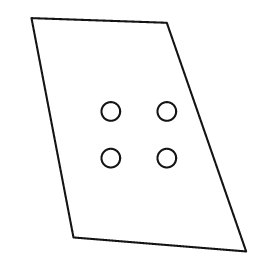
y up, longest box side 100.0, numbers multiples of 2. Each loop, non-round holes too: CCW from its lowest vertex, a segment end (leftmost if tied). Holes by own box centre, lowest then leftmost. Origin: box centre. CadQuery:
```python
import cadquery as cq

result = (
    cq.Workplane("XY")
    .moveTo(46.0, -50.0)
    .lineTo(12.0, 48.0)
    .lineTo(-46.0, 50.0)
    .lineTo(-28.0, -44.0)
    .close()
    .moveTo(-12.0, -10.0)
    .circle(4.0)
    .moveTo(12.0, -10.0)
    .circle(4.0)
    .moveTo(-12.0, 10.0)
    .circle(4.0)
    .moveTo(12.0, 10.0)
    .circle(4.0)
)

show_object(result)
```